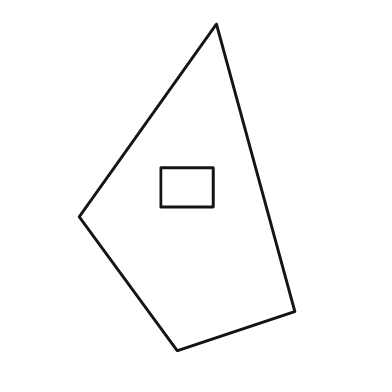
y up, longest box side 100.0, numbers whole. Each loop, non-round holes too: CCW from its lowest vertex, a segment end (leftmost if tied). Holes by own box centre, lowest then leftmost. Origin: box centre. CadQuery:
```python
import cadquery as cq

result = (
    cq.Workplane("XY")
    .moveTo(-3.0, -50.0)
    .lineTo(33.0, -38.0)
    .lineTo(9.0, 50.0)
    .lineTo(-33.0, -9.0)
    .close()
    .moveTo(-8.0, -6.0)
    .lineTo(8.0, -6.0)
    .lineTo(8.0, 6.0)
    .lineTo(-8.0, 6.0)
    .close()
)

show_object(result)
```